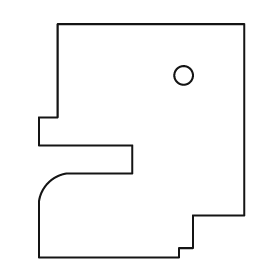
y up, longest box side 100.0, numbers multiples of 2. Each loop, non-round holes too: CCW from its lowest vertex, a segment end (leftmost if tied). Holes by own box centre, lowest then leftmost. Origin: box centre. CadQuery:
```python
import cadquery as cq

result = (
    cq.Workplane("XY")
    .moveTo(-44.0, -50.0)
    .lineTo(16.0, -50.0)
    .lineTo(16.0, -46.0)
    .lineTo(22.0, -46.0)
    .lineTo(22.0, -32.0)
    .lineTo(44.0, -32.0)
    .lineTo(44.0, 50.0)
    .lineTo(-36.0, 50.0)
    .lineTo(-36.0, 10.0)
    .lineTo(-44.0, 10.0)
    .lineTo(-44.0, -2.0)
    .lineTo(-4.0, -2.0)
    .lineTo(-4.0, -14.0)
    .lineTo(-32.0, -14.0)
    .threePointArc((-40.0, -18.0), (-44.0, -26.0))
    .close()
    .moveTo(18.0, 28.0)
    .circle(4.0)
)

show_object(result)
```